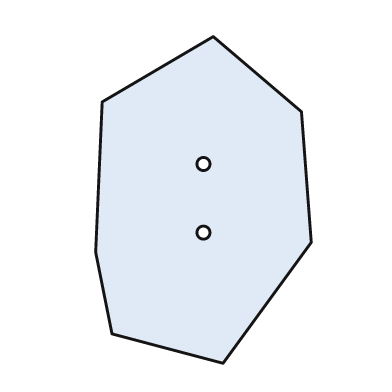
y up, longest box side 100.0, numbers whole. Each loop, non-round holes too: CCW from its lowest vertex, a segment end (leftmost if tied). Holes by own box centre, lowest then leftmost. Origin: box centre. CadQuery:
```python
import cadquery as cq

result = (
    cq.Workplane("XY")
    .moveTo(6.0, -50.0)
    .lineTo(33.0, -13.0)
    .lineTo(30.0, 27.0)
    .lineTo(3.0, 50.0)
    .lineTo(-31.0, 30.0)
    .lineTo(-33.0, -16.0)
    .lineTo(-28.0, -41.0)
    .close()
    .moveTo(0.0, -10.0)
    .circle(2.0)
    .moveTo(0.0, 11.0)
    .circle(2.0)
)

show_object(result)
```